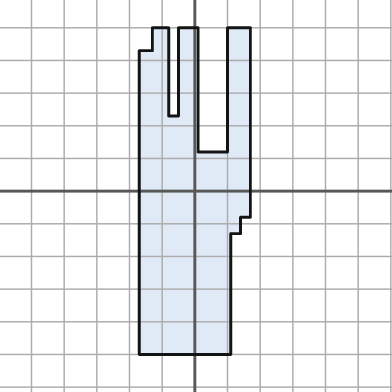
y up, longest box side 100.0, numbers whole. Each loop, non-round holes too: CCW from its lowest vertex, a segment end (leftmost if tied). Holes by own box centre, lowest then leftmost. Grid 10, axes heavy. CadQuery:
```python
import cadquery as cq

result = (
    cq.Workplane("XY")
    .moveTo(-17.0, -50.0)
    .lineTo(11.0, -50.0)
    .lineTo(11.0, -13.0)
    .lineTo(14.0, -13.0)
    .lineTo(14.0, -8.0)
    .lineTo(17.0, -8.0)
    .lineTo(17.0, 50.0)
    .lineTo(10.0, 50.0)
    .lineTo(10.0, 12.0)
    .lineTo(1.0, 12.0)
    .lineTo(1.0, 50.0)
    .lineTo(-5.0, 50.0)
    .lineTo(-5.0, 23.0)
    .lineTo(-8.0, 23.0)
    .lineTo(-8.0, 50.0)
    .lineTo(-13.0, 50.0)
    .lineTo(-13.0, 43.0)
    .lineTo(-17.0, 43.0)
    .close()
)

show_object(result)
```